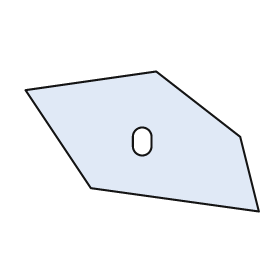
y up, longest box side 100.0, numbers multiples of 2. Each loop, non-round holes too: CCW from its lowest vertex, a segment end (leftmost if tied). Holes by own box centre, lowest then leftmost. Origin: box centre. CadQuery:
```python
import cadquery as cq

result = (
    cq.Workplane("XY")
    .moveTo(50.0, -30.0)
    .lineTo(42.0, 2.0)
    .lineTo(6.0, 30.0)
    .lineTo(-50.0, 22.0)
    .lineTo(-22.0, -20.0)
    .close()
    .moveTo(-4.0, -2.0)
    .threePointArc((0.0, -6.0), (4.0, -2.0))
    .lineTo(4.0, 2.0)
    .threePointArc((0.0, 6.0), (-4.0, 2.0))
    .close()
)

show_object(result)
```